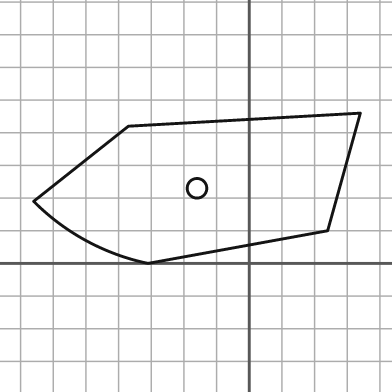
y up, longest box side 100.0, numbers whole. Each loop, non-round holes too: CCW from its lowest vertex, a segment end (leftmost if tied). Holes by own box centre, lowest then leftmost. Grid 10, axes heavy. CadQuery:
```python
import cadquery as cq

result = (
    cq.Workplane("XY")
    .moveTo(-31.0, 0.0)
    .lineTo(24.0, 10.0)
    .lineTo(34.0, 46.0)
    .lineTo(-37.0, 42.0)
    .lineTo(-66.0, 19.0)
    .threePointArc((-50.0, 7.0), (-31.0, 0.0))
    .close()
    .moveTo(-16.0, 23.0)
    .circle(3.0)
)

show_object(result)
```